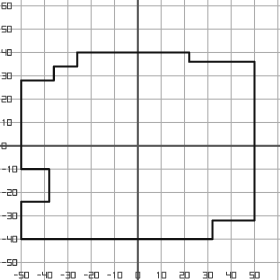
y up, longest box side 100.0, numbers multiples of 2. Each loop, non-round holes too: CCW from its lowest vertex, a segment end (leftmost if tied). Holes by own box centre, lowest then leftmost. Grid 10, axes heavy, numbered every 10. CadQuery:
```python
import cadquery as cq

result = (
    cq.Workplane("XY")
    .moveTo(-50.0, -40.0)
    .lineTo(32.0, -40.0)
    .lineTo(32.0, -32.0)
    .lineTo(50.0, -32.0)
    .lineTo(50.0, 36.0)
    .lineTo(22.0, 36.0)
    .lineTo(22.0, 40.0)
    .lineTo(-26.0, 40.0)
    .lineTo(-26.0, 34.0)
    .lineTo(-36.0, 34.0)
    .lineTo(-36.0, 28.0)
    .lineTo(-50.0, 28.0)
    .lineTo(-50.0, -10.0)
    .lineTo(-38.0, -10.0)
    .lineTo(-38.0, -24.0)
    .lineTo(-50.0, -24.0)
    .close()
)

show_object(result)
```